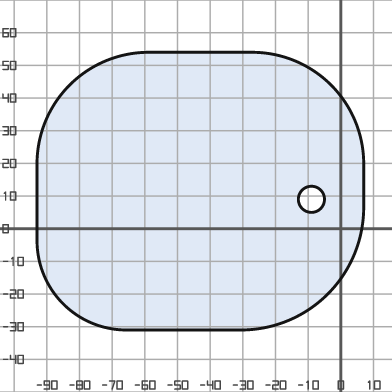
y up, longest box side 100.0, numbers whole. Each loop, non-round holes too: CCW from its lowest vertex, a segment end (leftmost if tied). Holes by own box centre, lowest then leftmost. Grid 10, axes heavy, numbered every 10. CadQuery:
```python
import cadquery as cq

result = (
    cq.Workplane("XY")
    .moveTo(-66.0, -31.0)
    .lineTo(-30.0, -31.0)
    .threePointArc((-4.0, -20.0), (7.0, 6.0))
    .lineTo(7.0, 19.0)
    .threePointArc((-3.0, 44.0), (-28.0, 54.0))
    .lineTo(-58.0, 54.0)
    .threePointArc((-83.0, 44.0), (-93.0, 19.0))
    .lineTo(-93.0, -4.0)
    .threePointArc((-85.0, -23.0), (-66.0, -31.0))
    .close()
    .moveTo(-9.0, 9.0)
    .circle(4.0)
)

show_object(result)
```